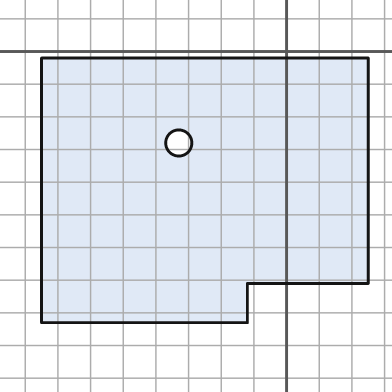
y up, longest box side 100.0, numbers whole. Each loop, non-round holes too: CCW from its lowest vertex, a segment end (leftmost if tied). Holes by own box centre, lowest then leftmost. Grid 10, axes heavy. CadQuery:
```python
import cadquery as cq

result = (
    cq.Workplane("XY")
    .moveTo(-75.0, -83.0)
    .lineTo(-12.0, -83.0)
    .lineTo(-12.0, -71.0)
    .lineTo(25.0, -71.0)
    .lineTo(25.0, -2.0)
    .lineTo(-75.0, -2.0)
    .close()
    .moveTo(-33.0, -28.0)
    .circle(4.0)
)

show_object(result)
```